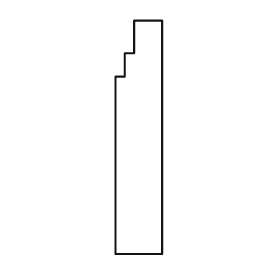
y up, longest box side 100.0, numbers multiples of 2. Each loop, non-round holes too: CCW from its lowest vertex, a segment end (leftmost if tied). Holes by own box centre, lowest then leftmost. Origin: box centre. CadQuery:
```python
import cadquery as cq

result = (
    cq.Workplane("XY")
    .moveTo(-10.0, -50.0)
    .lineTo(10.0, -50.0)
    .lineTo(10.0, 50.0)
    .lineTo(-2.0, 50.0)
    .lineTo(-2.0, 36.0)
    .lineTo(-6.0, 36.0)
    .lineTo(-6.0, 26.0)
    .lineTo(-10.0, 26.0)
    .close()
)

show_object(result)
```